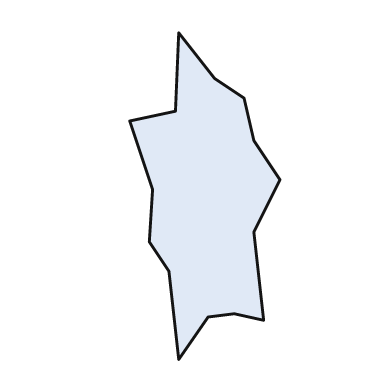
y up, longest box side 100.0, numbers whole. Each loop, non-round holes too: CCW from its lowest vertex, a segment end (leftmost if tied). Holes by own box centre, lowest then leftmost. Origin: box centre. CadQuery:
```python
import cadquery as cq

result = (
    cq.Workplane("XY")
    .moveTo(-8.0, -50.0)
    .lineTo(1.0, -37.0)
    .lineTo(9.0, -36.0)
    .lineTo(18.0, -38.0)
    .lineTo(15.0, -11.0)
    .lineTo(23.0, 5.0)
    .lineTo(15.0, 17.0)
    .lineTo(12.0, 30.0)
    .lineTo(3.0, 36.0)
    .lineTo(-8.0, 50.0)
    .lineTo(-9.0, 26.0)
    .lineTo(-23.0, 23.0)
    .lineTo(-16.0, 2.0)
    .lineTo(-17.0, -14.0)
    .lineTo(-11.0, -23.0)
    .close()
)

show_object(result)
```